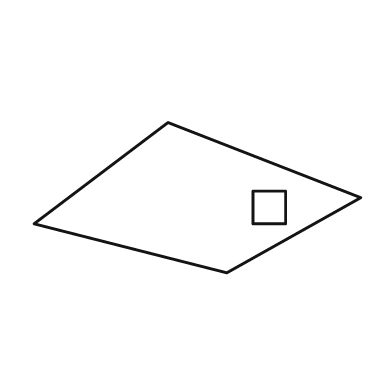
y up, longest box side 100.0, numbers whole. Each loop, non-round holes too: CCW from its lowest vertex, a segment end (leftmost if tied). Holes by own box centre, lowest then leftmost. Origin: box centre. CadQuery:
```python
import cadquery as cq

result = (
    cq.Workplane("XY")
    .moveTo(9.0, -23.0)
    .lineTo(50.0, 0.0)
    .lineTo(-9.0, 23.0)
    .lineTo(-50.0, -8.0)
    .close()
    .moveTo(17.0, -8.0)
    .lineTo(27.0, -8.0)
    .lineTo(27.0, 2.0)
    .lineTo(17.0, 2.0)
    .close()
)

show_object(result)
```